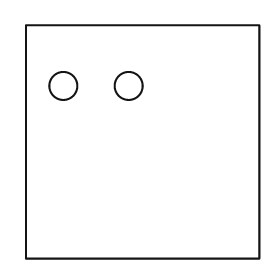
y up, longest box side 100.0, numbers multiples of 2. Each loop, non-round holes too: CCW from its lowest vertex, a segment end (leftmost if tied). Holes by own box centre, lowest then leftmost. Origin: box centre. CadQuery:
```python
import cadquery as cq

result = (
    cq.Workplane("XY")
    .moveTo(-50.0, -50.0)
    .lineTo(50.0, -50.0)
    .lineTo(50.0, 50.0)
    .lineTo(-50.0, 50.0)
    .close()
    .moveTo(-34.0, 24.0)
    .circle(6.0)
    .moveTo(-6.0, 24.0)
    .circle(6.0)
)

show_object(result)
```